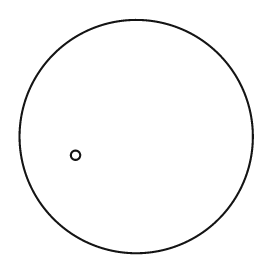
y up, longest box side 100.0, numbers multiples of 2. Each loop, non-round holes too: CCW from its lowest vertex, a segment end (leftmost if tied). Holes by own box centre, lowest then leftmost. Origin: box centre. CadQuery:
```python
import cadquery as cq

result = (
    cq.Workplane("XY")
    .moveTo(0.0, 0.0)
    .circle(50.0)
    .moveTo(-26.0, -8.0)
    .circle(2.0)
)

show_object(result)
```